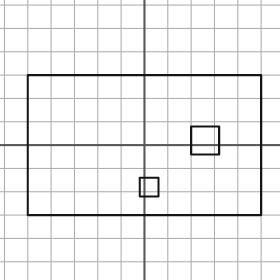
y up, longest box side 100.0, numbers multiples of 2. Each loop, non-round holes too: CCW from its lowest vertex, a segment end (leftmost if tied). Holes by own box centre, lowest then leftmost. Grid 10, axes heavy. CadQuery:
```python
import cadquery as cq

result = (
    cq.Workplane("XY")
    .moveTo(-50.0, -30.0)
    .lineTo(50.0, -30.0)
    .lineTo(50.0, 30.0)
    .lineTo(-50.0, 30.0)
    .close()
    .moveTo(-2.0, -22.0)
    .lineTo(6.0, -22.0)
    .lineTo(6.0, -14.0)
    .lineTo(-2.0, -14.0)
    .close()
    .moveTo(20.0, -4.0)
    .lineTo(32.0, -4.0)
    .lineTo(32.0, 8.0)
    .lineTo(20.0, 8.0)
    .close()
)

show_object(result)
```